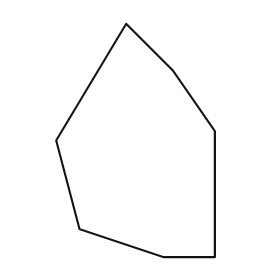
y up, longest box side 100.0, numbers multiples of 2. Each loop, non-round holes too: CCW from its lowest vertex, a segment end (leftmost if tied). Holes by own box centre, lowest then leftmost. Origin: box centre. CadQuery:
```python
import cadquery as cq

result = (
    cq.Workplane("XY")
    .moveTo(12.0, -50.0)
    .lineTo(34.0, -50.0)
    .lineTo(34.0, 4.0)
    .lineTo(16.0, 30.0)
    .lineTo(-4.0, 50.0)
    .lineTo(-34.0, 0.0)
    .lineTo(-24.0, -38.0)
    .close()
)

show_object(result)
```